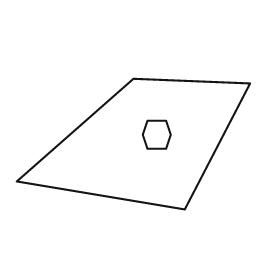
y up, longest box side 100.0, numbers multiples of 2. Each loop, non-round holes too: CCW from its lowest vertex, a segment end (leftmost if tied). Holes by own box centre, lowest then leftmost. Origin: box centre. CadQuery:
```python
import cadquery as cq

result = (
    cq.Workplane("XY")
    .moveTo(22.0, -28.0)
    .lineTo(50.0, 26.0)
    .lineTo(0.0, 28.0)
    .lineTo(-50.0, -16.0)
    .close()
    .moveTo(6.0, -2.0)
    .lineTo(14.0, -2.0)
    .lineTo(16.0, 4.0)
    .lineTo(14.0, 10.0)
    .lineTo(6.0, 10.0)
    .lineTo(4.0, 4.0)
    .close()
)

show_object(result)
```